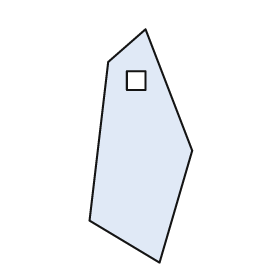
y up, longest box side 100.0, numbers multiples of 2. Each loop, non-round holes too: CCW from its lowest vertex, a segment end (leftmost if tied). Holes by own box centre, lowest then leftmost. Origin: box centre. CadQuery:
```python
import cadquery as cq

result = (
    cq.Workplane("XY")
    .moveTo(8.0, -50.0)
    .lineTo(22.0, -2.0)
    .lineTo(2.0, 50.0)
    .lineTo(-14.0, 36.0)
    .lineTo(-22.0, -32.0)
    .close()
    .moveTo(-6.0, 24.0)
    .lineTo(2.0, 24.0)
    .lineTo(2.0, 32.0)
    .lineTo(-6.0, 32.0)
    .close()
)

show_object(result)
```